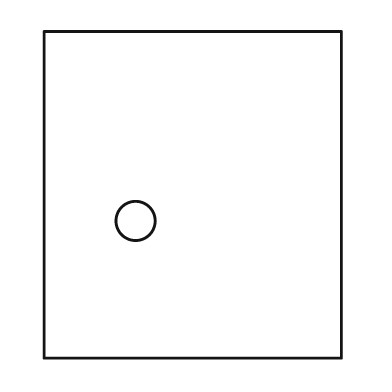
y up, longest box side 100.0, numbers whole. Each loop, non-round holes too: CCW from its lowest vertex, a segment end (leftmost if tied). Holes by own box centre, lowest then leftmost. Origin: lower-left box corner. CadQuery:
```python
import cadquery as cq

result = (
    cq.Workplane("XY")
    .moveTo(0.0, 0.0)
    .lineTo(91.0, 0.0)
    .lineTo(91.0, 100.0)
    .lineTo(0.0, 100.0)
    .close()
    .moveTo(28.0, 42.0)
    .circle(6.0)
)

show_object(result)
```